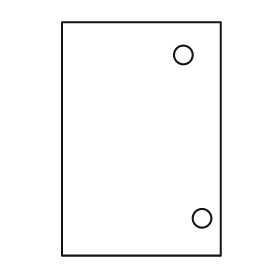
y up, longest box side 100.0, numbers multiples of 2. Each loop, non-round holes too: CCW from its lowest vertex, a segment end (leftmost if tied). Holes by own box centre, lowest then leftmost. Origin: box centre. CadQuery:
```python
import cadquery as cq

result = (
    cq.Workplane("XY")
    .moveTo(-34.0, -50.0)
    .lineTo(34.0, -50.0)
    .lineTo(34.0, 50.0)
    .lineTo(-34.0, 50.0)
    .close()
    .moveTo(26.0, -34.0)
    .circle(4.0)
    .moveTo(18.0, 36.0)
    .circle(4.0)
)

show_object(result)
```